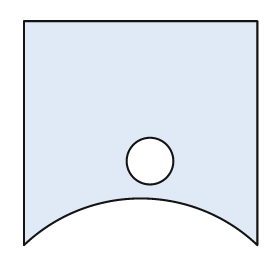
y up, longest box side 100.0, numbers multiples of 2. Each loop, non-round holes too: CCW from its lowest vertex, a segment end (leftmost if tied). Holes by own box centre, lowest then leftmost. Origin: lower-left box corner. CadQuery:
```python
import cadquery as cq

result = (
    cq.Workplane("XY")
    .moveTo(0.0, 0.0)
    .threePointArc((50.0, 20.0), (100.0, 0.0))
    .lineTo(100.0, 96.0)
    .lineTo(0.0, 96.0)
    .close()
    .moveTo(54.0, 36.0)
    .circle(10.0)
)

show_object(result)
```